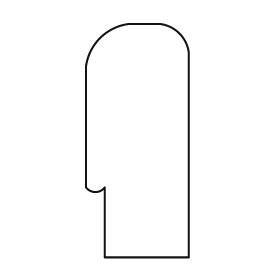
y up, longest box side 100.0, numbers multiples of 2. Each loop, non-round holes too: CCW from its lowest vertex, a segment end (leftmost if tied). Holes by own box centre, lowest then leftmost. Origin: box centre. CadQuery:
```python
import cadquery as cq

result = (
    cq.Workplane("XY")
    .moveTo(-14.0, -50.0)
    .lineTo(22.0, -50.0)
    .lineTo(22.0, 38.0)
    .threePointArc((18.0, 46.0), (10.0, 50.0))
    .lineTo(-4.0, 50.0)
    .threePointArc((-16.0, 44.0), (-22.0, 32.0))
    .lineTo(-22.0, -20.0)
    .threePointArc((-18.0, -22.0), (-14.0, -20.0))
    .close()
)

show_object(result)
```